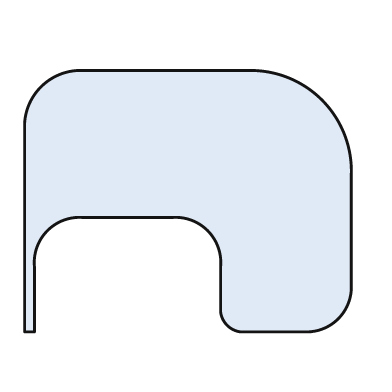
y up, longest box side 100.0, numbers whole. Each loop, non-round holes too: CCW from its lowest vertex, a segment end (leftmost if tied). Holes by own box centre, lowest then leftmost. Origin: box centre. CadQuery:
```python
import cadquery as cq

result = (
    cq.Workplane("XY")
    .moveTo(-50.0, -40.0)
    .lineTo(-47.0, -40.0)
    .lineTo(-47.0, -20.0)
    .threePointArc((-43.0, -9.0), (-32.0, -5.0))
    .lineTo(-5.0, -5.0)
    .threePointArc((6.0, -9.0), (10.0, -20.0))
    .lineTo(10.0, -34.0)
    .threePointArc((12.0, -38.0), (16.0, -40.0))
    .lineTo(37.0, -40.0)
    .threePointArc((46.0, -36.0), (50.0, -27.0))
    .lineTo(50.0, 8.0)
    .threePointArc((41.0, 31.0), (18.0, 40.0))
    .lineTo(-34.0, 40.0)
    .threePointArc((-45.0, 35.0), (-50.0, 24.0))
    .close()
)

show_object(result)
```